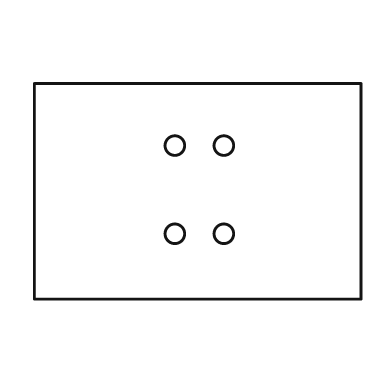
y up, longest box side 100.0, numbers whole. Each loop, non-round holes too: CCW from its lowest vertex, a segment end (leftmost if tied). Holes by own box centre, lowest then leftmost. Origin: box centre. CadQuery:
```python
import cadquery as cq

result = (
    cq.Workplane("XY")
    .moveTo(-50.0, -33.0)
    .lineTo(50.0, -33.0)
    .lineTo(50.0, 33.0)
    .lineTo(-50.0, 33.0)
    .close()
    .moveTo(-7.0, -13.0)
    .circle(3.0)
    .moveTo(8.0, -13.0)
    .circle(3.0)
    .moveTo(-7.0, 14.0)
    .circle(3.0)
    .moveTo(8.0, 14.0)
    .circle(3.0)
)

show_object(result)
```